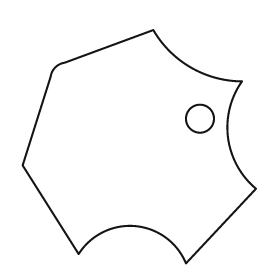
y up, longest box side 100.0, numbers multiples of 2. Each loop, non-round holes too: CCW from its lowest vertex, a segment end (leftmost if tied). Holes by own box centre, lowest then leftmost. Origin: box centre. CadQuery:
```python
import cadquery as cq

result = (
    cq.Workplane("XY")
    .moveTo(20.0, -50.0)
    .lineTo(50.0, -18.0)
    .threePointArc((38.0, 4.0), (44.0, 28.0))
    .threePointArc((22.0, 34.0), (6.0, 50.0))
    .lineTo(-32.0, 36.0)
    .threePointArc((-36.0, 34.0), (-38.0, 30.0))
    .lineTo(-50.0, -8.0)
    .lineTo(-26.0, -46.0)
    .threePointArc((-2.0, -34.0), (20.0, -50.0))
    .close()
    .moveTo(26.0, 12.0)
    .circle(6.0)
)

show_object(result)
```